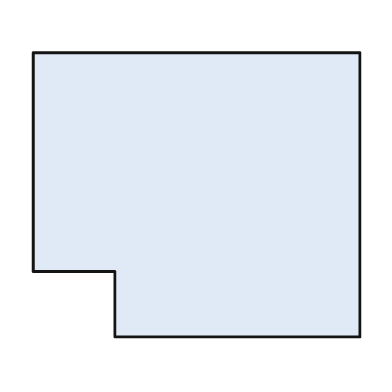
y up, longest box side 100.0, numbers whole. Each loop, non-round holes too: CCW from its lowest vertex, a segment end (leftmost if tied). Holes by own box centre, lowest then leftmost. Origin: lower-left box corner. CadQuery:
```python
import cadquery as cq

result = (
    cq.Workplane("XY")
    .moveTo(25.0, 0.0)
    .lineTo(100.0, 0.0)
    .lineTo(100.0, 87.0)
    .lineTo(0.0, 87.0)
    .lineTo(0.0, 20.0)
    .lineTo(25.0, 20.0)
    .close()
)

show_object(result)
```